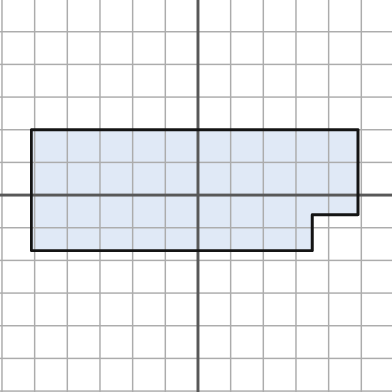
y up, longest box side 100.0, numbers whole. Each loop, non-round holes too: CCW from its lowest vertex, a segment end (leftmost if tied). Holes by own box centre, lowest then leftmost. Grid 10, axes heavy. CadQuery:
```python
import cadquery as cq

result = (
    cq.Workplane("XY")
    .moveTo(-51.0, -17.0)
    .lineTo(35.0, -17.0)
    .lineTo(35.0, -6.0)
    .lineTo(49.0, -6.0)
    .lineTo(49.0, 20.0)
    .lineTo(-51.0, 20.0)
    .close()
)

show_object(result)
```